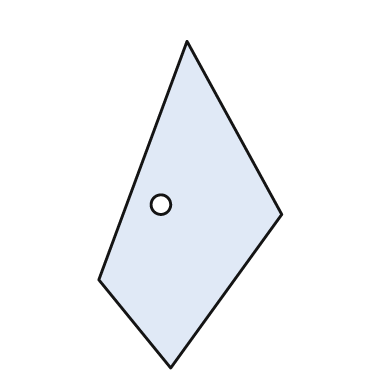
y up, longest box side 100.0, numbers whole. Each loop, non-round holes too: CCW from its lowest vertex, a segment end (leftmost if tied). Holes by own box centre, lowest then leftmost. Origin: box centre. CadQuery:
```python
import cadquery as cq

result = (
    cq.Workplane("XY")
    .moveTo(-6.0, -50.0)
    .lineTo(28.0, -3.0)
    .lineTo(-1.0, 50.0)
    .lineTo(-28.0, -23.0)
    .close()
    .moveTo(-9.0, 0.0)
    .circle(3.0)
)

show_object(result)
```